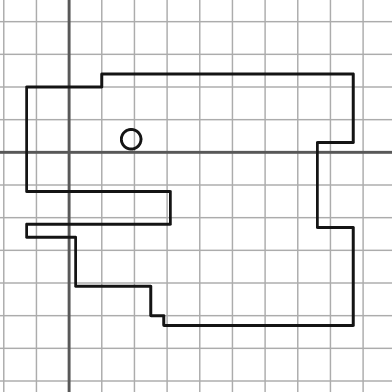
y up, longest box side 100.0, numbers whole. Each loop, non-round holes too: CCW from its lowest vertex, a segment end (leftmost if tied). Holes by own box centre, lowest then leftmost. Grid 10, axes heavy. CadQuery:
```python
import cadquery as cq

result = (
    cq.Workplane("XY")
    .moveTo(29.0, -53.0)
    .lineTo(87.0, -53.0)
    .lineTo(87.0, -23.0)
    .lineTo(76.0, -23.0)
    .lineTo(76.0, 3.0)
    .lineTo(87.0, 3.0)
    .lineTo(87.0, 24.0)
    .lineTo(10.0, 24.0)
    .lineTo(10.0, 20.0)
    .lineTo(-13.0, 20.0)
    .lineTo(-13.0, -12.0)
    .lineTo(31.0, -12.0)
    .lineTo(31.0, -22.0)
    .lineTo(-13.0, -22.0)
    .lineTo(-13.0, -26.0)
    .lineTo(2.0, -26.0)
    .lineTo(2.0, -41.0)
    .lineTo(25.0, -41.0)
    .lineTo(25.0, -50.0)
    .lineTo(29.0, -50.0)
    .close()
    .moveTo(19.0, 4.0)
    .circle(3.0)
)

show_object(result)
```